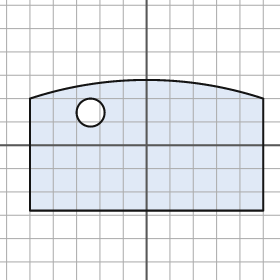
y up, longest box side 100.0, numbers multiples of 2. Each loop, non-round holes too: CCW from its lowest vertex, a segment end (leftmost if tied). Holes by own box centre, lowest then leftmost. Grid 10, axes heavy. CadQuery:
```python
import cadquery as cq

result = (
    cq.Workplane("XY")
    .moveTo(-50.0, -28.0)
    .lineTo(50.0, -28.0)
    .lineTo(50.0, 20.0)
    .threePointArc((0.0, 28.0), (-50.0, 20.0))
    .close()
    .moveTo(-24.0, 14.0)
    .circle(6.0)
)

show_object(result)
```